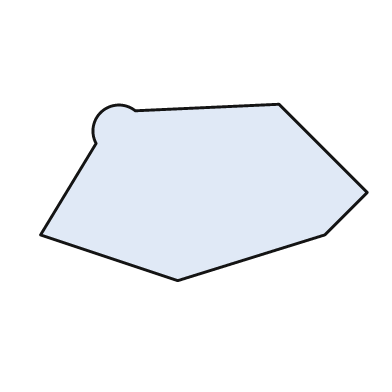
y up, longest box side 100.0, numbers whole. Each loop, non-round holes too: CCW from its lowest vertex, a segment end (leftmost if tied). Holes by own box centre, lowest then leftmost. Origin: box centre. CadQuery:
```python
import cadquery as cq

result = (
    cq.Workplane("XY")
    .moveTo(-8.0, -27.0)
    .lineTo(37.0, -13.0)
    .lineTo(50.0, 0.0)
    .lineTo(23.0, 27.0)
    .lineTo(-21.0, 25.0)
    .threePointArc((-31.0, 25.0), (-33.0, 15.0))
    .lineTo(-50.0, -13.0)
    .close()
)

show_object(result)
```